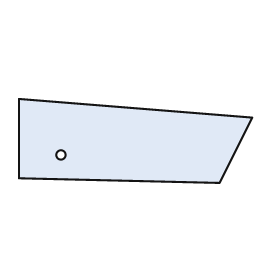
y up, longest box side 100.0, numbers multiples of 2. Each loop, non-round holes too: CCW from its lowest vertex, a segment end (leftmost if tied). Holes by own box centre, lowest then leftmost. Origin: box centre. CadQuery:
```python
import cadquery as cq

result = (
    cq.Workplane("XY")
    .moveTo(36.0, -18.0)
    .lineTo(50.0, 10.0)
    .lineTo(-50.0, 18.0)
    .lineTo(-50.0, -16.0)
    .close()
    .moveTo(-32.0, -6.0)
    .circle(2.0)
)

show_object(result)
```